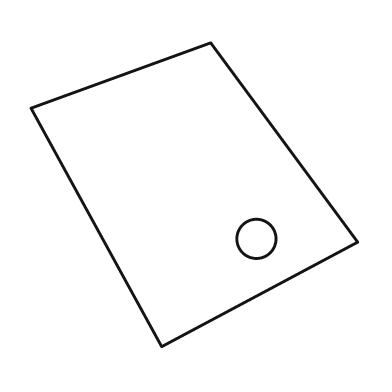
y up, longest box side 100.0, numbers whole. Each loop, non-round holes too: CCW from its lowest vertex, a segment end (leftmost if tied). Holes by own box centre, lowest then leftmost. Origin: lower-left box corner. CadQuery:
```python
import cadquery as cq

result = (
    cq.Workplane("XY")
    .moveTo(40.0, 0.0)
    .lineTo(100.0, 32.0)
    .lineTo(55.0, 93.0)
    .lineTo(0.0, 73.0)
    .close()
    .moveTo(69.0, 33.0)
    .circle(6.0)
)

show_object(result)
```